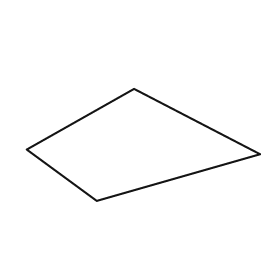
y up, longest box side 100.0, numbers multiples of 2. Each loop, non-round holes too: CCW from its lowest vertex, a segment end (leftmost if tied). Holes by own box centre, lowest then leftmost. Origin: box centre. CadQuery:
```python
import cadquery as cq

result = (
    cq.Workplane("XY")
    .moveTo(-20.0, -24.0)
    .lineTo(50.0, -4.0)
    .lineTo(-4.0, 24.0)
    .lineTo(-50.0, -2.0)
    .close()
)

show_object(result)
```